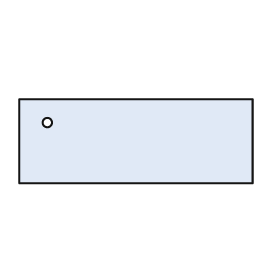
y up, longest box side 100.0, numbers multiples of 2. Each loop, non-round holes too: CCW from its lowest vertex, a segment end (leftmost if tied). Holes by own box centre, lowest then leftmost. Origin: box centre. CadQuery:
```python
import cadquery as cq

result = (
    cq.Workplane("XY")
    .moveTo(-50.0, -18.0)
    .lineTo(50.0, -18.0)
    .lineTo(50.0, 18.0)
    .lineTo(-50.0, 18.0)
    .close()
    .moveTo(-38.0, 8.0)
    .circle(2.0)
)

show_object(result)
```